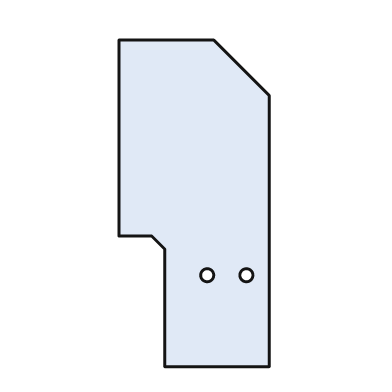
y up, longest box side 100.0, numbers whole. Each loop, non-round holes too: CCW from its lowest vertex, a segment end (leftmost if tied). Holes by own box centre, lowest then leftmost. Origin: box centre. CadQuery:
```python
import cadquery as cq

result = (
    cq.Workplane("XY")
    .moveTo(-9.0, -50.0)
    .lineTo(23.0, -50.0)
    .lineTo(23.0, 33.0)
    .lineTo(6.0, 50.0)
    .lineTo(-23.0, 50.0)
    .lineTo(-23.0, -10.0)
    .lineTo(-13.0, -10.0)
    .lineTo(-9.0, -14.0)
    .close()
    .moveTo(4.0, -22.0)
    .circle(2.0)
    .moveTo(16.0, -22.0)
    .circle(2.0)
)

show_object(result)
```